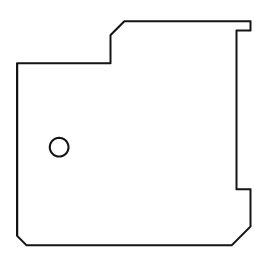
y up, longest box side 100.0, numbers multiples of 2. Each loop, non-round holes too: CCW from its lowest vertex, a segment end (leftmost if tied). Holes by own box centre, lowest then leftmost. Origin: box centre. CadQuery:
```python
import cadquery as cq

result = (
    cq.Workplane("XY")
    .moveTo(-46.0, -48.0)
    .lineTo(42.0, -48.0)
    .lineTo(50.0, -40.0)
    .lineTo(50.0, -24.0)
    .lineTo(44.0, -24.0)
    .lineTo(44.0, 44.0)
    .lineTo(50.0, 44.0)
    .lineTo(50.0, 48.0)
    .lineTo(-4.0, 48.0)
    .lineTo(-10.0, 42.0)
    .lineTo(-10.0, 30.0)
    .lineTo(-50.0, 30.0)
    .lineTo(-50.0, -44.0)
    .close()
    .moveTo(-32.0, -6.0)
    .circle(4.0)
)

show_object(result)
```